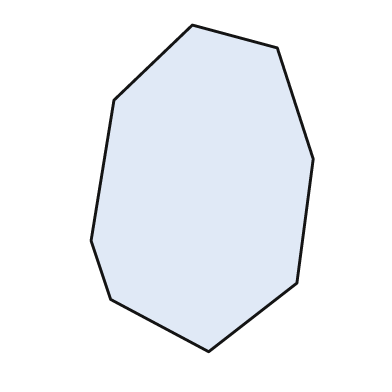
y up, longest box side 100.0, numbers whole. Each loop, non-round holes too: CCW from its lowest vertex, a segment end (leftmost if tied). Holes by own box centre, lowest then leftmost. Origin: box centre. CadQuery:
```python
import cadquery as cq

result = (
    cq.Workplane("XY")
    .moveTo(2.0, -50.0)
    .lineTo(29.0, -29.0)
    .lineTo(34.0, 9.0)
    .lineTo(23.0, 43.0)
    .lineTo(-3.0, 50.0)
    .lineTo(-27.0, 27.0)
    .lineTo(-34.0, -16.0)
    .lineTo(-28.0, -34.0)
    .close()
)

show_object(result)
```